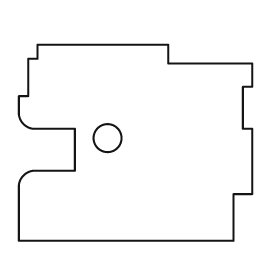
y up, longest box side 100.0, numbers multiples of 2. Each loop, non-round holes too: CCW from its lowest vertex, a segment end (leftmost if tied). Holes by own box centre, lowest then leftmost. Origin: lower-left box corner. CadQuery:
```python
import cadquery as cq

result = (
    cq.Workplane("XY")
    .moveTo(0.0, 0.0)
    .lineTo(92.0, 0.0)
    .lineTo(92.0, 20.0)
    .lineTo(100.0, 20.0)
    .lineTo(100.0, 48.0)
    .lineTo(96.0, 48.0)
    .lineTo(96.0, 66.0)
    .lineTo(100.0, 66.0)
    .lineTo(100.0, 76.0)
    .lineTo(64.0, 76.0)
    .lineTo(64.0, 84.0)
    .lineTo(8.0, 84.0)
    .lineTo(8.0, 78.0)
    .lineTo(4.0, 78.0)
    .lineTo(4.0, 62.0)
    .lineTo(0.0, 62.0)
    .lineTo(0.0, 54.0)
    .threePointArc((2.0, 50.0), (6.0, 48.0))
    .lineTo(24.0, 48.0)
    .lineTo(24.0, 30.0)
    .lineTo(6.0, 30.0)
    .threePointArc((2.0, 28.0), (0.0, 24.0))
    .close()
    .moveTo(38.0, 44.0)
    .circle(6.0)
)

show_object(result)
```